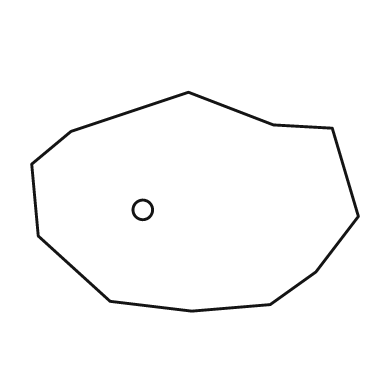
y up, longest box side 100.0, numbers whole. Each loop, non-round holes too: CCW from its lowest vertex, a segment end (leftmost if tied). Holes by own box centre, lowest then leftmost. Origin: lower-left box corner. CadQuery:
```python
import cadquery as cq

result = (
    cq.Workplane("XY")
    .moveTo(49.0, 0.0)
    .lineTo(73.0, 2.0)
    .lineTo(87.0, 12.0)
    .lineTo(100.0, 29.0)
    .lineTo(92.0, 56.0)
    .lineTo(74.0, 57.0)
    .lineTo(48.0, 67.0)
    .lineTo(12.0, 55.0)
    .lineTo(0.0, 45.0)
    .lineTo(2.0, 23.0)
    .lineTo(24.0, 3.0)
    .close()
    .moveTo(34.0, 31.0)
    .circle(3.0)
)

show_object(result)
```